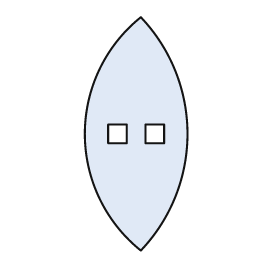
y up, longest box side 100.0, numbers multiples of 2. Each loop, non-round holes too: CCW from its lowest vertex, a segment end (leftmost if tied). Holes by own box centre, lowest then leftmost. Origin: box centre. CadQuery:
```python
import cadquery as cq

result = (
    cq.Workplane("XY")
    .moveTo(2.0, -50.0)
    .threePointArc((22.0, 0.0), (2.0, 50.0))
    .threePointArc((-22.0, 0.0), (2.0, -50.0))
    .close()
    .moveTo(-12.0, -4.0)
    .lineTo(-4.0, -4.0)
    .lineTo(-4.0, 4.0)
    .lineTo(-12.0, 4.0)
    .close()
    .moveTo(4.0, -4.0)
    .lineTo(12.0, -4.0)
    .lineTo(12.0, 4.0)
    .lineTo(4.0, 4.0)
    .close()
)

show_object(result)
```